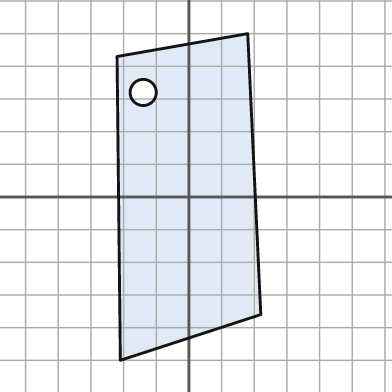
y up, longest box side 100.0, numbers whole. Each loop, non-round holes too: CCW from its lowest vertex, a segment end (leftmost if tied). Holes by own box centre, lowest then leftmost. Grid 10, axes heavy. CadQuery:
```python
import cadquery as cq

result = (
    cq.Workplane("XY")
    .moveTo(-21.0, -50.0)
    .lineTo(22.0, -36.0)
    .lineTo(18.0, 50.0)
    .lineTo(-22.0, 43.0)
    .close()
    .moveTo(-14.0, 32.0)
    .circle(4.0)
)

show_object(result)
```